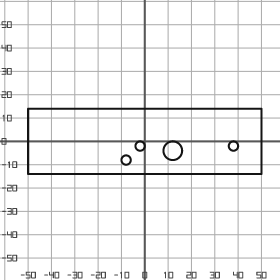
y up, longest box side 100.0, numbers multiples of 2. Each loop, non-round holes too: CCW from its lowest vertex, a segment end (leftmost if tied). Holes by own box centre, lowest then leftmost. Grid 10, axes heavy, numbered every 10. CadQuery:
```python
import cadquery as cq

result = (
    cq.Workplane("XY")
    .moveTo(-50.0, -14.0)
    .lineTo(50.0, -14.0)
    .lineTo(50.0, 14.0)
    .lineTo(-50.0, 14.0)
    .close()
    .moveTo(-8.0, -8.0)
    .circle(2.0)
    .moveTo(12.0, -4.0)
    .circle(4.0)
    .moveTo(-2.0, -2.0)
    .circle(2.0)
    .moveTo(38.0, -2.0)
    .circle(2.0)
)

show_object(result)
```